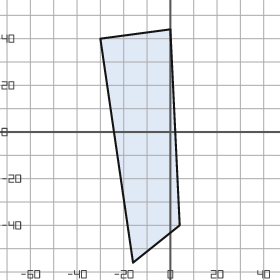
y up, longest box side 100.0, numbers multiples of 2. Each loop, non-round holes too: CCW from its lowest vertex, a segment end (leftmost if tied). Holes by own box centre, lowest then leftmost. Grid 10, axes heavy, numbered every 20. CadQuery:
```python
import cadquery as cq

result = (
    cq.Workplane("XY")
    .moveTo(-16.0, -56.0)
    .lineTo(4.0, -40.0)
    .lineTo(0.0, 44.0)
    .lineTo(-30.0, 40.0)
    .close()
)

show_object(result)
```